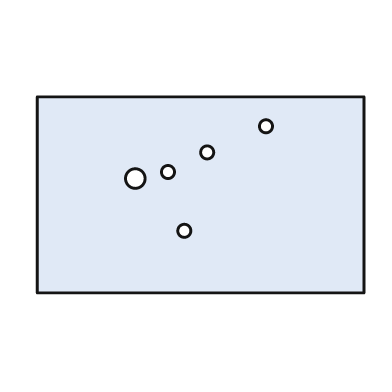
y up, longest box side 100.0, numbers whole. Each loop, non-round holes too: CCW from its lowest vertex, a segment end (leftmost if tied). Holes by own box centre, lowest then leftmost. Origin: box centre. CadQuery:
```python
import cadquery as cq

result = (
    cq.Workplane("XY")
    .moveTo(-50.0, -30.0)
    .lineTo(50.0, -30.0)
    .lineTo(50.0, 30.0)
    .lineTo(-50.0, 30.0)
    .close()
    .moveTo(-5.0, -11.0)
    .circle(2.0)
    .moveTo(-20.0, 5.0)
    .circle(3.0)
    .moveTo(-10.0, 7.0)
    .circle(2.0)
    .moveTo(2.0, 13.0)
    .circle(2.0)
    .moveTo(20.0, 21.0)
    .circle(2.0)
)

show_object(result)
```